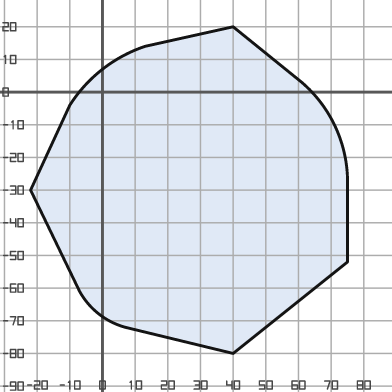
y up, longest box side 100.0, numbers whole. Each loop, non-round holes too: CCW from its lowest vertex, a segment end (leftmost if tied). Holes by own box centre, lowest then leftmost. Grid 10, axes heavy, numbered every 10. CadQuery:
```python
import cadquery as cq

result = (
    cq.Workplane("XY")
    .moveTo(40.0, -80.0)
    .lineTo(75.0, -52.0)
    .lineTo(75.0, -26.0)
    .threePointArc((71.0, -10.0), (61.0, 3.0))
    .lineTo(40.0, 20.0)
    .lineTo(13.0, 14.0)
    .threePointArc((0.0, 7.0), (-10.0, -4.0))
    .lineTo(-22.0, -30.0)
    .lineTo(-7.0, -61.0)
    .threePointArc((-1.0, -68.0), (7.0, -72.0))
    .close()
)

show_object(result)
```